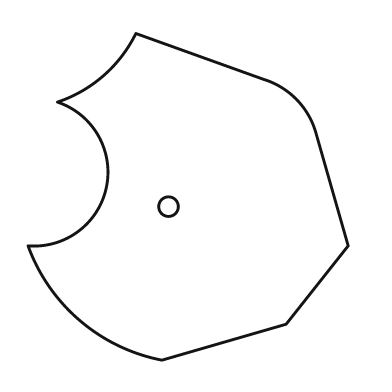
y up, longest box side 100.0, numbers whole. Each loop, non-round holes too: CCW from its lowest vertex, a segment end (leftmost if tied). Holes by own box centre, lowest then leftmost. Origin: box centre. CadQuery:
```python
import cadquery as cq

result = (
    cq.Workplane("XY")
    .moveTo(-8.0, -50.0)
    .lineTo(30.0, -39.0)
    .lineTo(49.0, -15.0)
    .lineTo(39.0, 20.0)
    .threePointArc((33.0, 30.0), (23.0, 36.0))
    .lineTo(-16.0, 50.0)
    .threePointArc((-26.0, 37.0), (-40.0, 29.0))
    .threePointArc((-25.0, 3.0), (-49.0, -15.0))
    .threePointArc((-33.0, -38.0), (-8.0, -50.0))
    .close()
    .moveTo(-6.0, -3.0)
    .circle(3.0)
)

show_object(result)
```